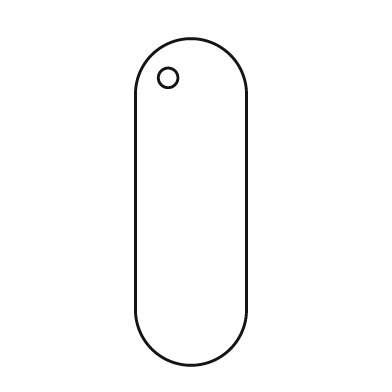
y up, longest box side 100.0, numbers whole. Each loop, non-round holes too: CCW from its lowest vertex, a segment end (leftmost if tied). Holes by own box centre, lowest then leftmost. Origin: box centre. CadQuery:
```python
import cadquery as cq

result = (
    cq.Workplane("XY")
    .moveTo(-17.0, -33.0)
    .threePointArc((0.0, -50.0), (17.0, -33.0))
    .lineTo(17.0, 33.0)
    .threePointArc((0.0, 50.0), (-17.0, 33.0))
    .close()
    .moveTo(-7.0, 38.0)
    .circle(3.0)
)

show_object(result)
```